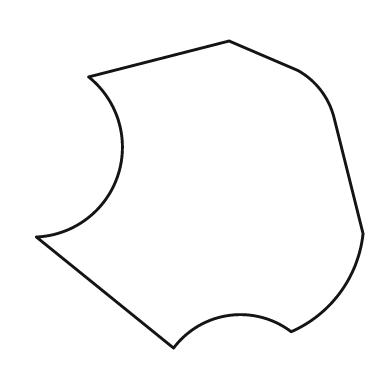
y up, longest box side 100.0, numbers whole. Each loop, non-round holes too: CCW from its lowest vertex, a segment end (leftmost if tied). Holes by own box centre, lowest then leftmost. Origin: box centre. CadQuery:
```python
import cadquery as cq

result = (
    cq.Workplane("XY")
    .moveTo(-8.0, -47.0)
    .threePointArc((9.0, -37.0), (28.0, -42.0))
    .threePointArc((43.0, -30.0), (50.0, -12.0))
    .lineTo(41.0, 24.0)
    .threePointArc((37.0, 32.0), (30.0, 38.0))
    .lineTo(9.0, 47.0)
    .lineTo(-34.0, 36.0)
    .threePointArc((-25.0, 6.0), (-50.0, -13.0))
    .close()
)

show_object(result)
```